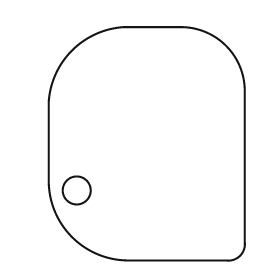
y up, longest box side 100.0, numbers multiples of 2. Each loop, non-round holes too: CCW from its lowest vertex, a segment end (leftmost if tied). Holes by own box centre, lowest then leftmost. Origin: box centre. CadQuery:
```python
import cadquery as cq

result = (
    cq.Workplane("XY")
    .moveTo(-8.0, -50.0)
    .lineTo(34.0, -50.0)
    .threePointArc((40.0, -48.0), (42.0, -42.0))
    .lineTo(42.0, 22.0)
    .threePointArc((34.0, 42.0), (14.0, 50.0))
    .lineTo(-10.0, 50.0)
    .threePointArc((-32.0, 40.0), (-42.0, 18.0))
    .lineTo(-42.0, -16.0)
    .threePointArc((-32.0, -40.0), (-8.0, -50.0))
    .close()
    .moveTo(-30.0, -20.0)
    .circle(6.0)
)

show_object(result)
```